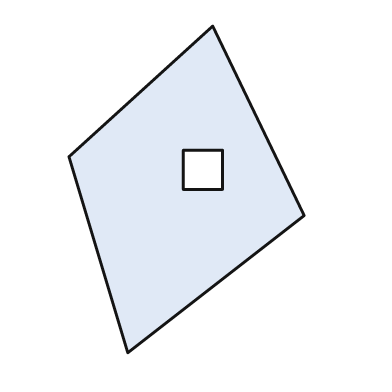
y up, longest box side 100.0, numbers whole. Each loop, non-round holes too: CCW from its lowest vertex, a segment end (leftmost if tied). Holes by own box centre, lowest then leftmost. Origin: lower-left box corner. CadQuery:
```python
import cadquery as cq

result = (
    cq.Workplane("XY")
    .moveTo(18.0, 0.0)
    .lineTo(72.0, 42.0)
    .lineTo(44.0, 100.0)
    .lineTo(0.0, 60.0)
    .close()
    .moveTo(35.0, 50.0)
    .lineTo(47.0, 50.0)
    .lineTo(47.0, 62.0)
    .lineTo(35.0, 62.0)
    .close()
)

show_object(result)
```